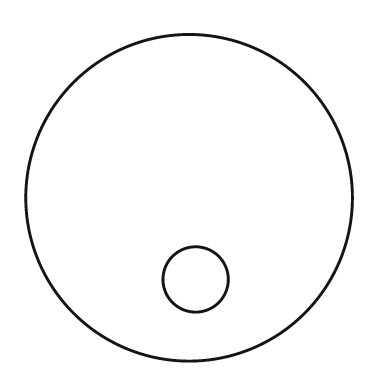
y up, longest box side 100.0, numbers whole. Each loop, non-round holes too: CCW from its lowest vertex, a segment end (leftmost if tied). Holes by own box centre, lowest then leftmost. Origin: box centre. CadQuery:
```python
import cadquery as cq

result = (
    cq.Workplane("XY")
    .moveTo(0.0, 0.0)
    .circle(50.0)
    .moveTo(2.0, -25.0)
    .circle(10.0)
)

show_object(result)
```